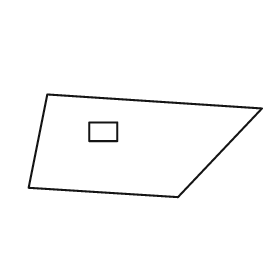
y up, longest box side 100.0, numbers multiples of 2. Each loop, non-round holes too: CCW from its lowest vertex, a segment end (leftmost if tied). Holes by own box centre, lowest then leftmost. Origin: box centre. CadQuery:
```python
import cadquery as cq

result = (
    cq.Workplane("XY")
    .moveTo(14.0, -22.0)
    .lineTo(50.0, 16.0)
    .lineTo(-42.0, 22.0)
    .lineTo(-50.0, -18.0)
    .close()
    .moveTo(-24.0, 2.0)
    .lineTo(-12.0, 2.0)
    .lineTo(-12.0, 10.0)
    .lineTo(-24.0, 10.0)
    .close()
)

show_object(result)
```